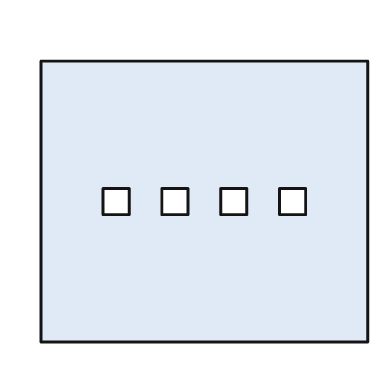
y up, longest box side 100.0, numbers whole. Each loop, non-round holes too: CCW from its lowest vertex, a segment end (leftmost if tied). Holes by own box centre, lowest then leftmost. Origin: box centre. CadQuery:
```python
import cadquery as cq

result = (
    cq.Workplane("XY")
    .moveTo(-50.0, -43.0)
    .lineTo(50.0, -43.0)
    .lineTo(50.0, 43.0)
    .lineTo(-50.0, 43.0)
    .close()
    .moveTo(-31.0, -4.0)
    .lineTo(-23.0, -4.0)
    .lineTo(-23.0, 4.0)
    .lineTo(-31.0, 4.0)
    .close()
    .moveTo(-13.0, -4.0)
    .lineTo(-5.0, -4.0)
    .lineTo(-5.0, 4.0)
    .lineTo(-13.0, 4.0)
    .close()
    .moveTo(5.0, -4.0)
    .lineTo(13.0, -4.0)
    .lineTo(13.0, 4.0)
    .lineTo(5.0, 4.0)
    .close()
    .moveTo(23.0, -4.0)
    .lineTo(31.0, -4.0)
    .lineTo(31.0, 4.0)
    .lineTo(23.0, 4.0)
    .close()
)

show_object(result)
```